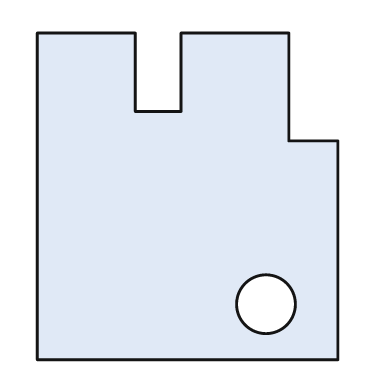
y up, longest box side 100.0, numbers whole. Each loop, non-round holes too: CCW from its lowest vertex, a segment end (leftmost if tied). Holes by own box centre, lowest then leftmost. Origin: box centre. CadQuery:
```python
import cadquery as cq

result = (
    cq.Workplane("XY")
    .moveTo(-46.0, -50.0)
    .lineTo(46.0, -50.0)
    .lineTo(46.0, 17.0)
    .lineTo(31.0, 17.0)
    .lineTo(31.0, 50.0)
    .lineTo(-2.0, 50.0)
    .lineTo(-2.0, 26.0)
    .lineTo(-16.0, 26.0)
    .lineTo(-16.0, 50.0)
    .lineTo(-46.0, 50.0)
    .close()
    .moveTo(24.0, -33.0)
    .circle(9.0)
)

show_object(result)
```